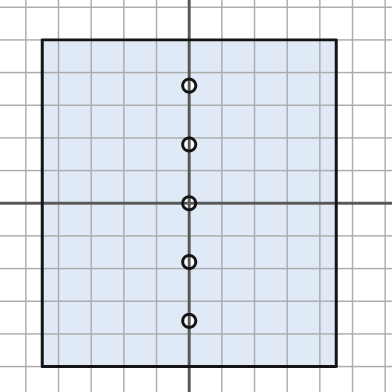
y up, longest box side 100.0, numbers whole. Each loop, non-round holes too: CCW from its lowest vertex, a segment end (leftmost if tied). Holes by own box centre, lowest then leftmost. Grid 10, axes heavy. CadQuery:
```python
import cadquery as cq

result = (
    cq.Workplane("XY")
    .moveTo(-45.0, -50.0)
    .lineTo(45.0, -50.0)
    .lineTo(45.0, 50.0)
    .lineTo(-45.0, 50.0)
    .close()
    .moveTo(0.0, -36.0)
    .circle(2.0)
    .moveTo(0.0, -18.0)
    .circle(2.0)
    .moveTo(0.0, 0.0)
    .circle(2.0)
    .moveTo(0.0, 18.0)
    .circle(2.0)
    .moveTo(0.0, 36.0)
    .circle(2.0)
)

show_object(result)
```